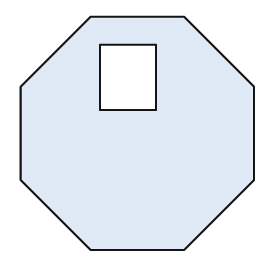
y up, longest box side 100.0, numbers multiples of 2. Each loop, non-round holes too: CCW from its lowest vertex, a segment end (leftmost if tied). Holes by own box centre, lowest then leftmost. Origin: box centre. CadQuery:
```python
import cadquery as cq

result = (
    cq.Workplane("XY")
    .moveTo(-20.0, -50.0)
    .lineTo(20.0, -50.0)
    .lineTo(50.0, -20.0)
    .lineTo(50.0, 20.0)
    .lineTo(20.0, 50.0)
    .lineTo(-20.0, 50.0)
    .lineTo(-50.0, 20.0)
    .lineTo(-50.0, -20.0)
    .close()
    .moveTo(-16.0, 10.0)
    .lineTo(8.0, 10.0)
    .lineTo(8.0, 38.0)
    .lineTo(-16.0, 38.0)
    .close()
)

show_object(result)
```